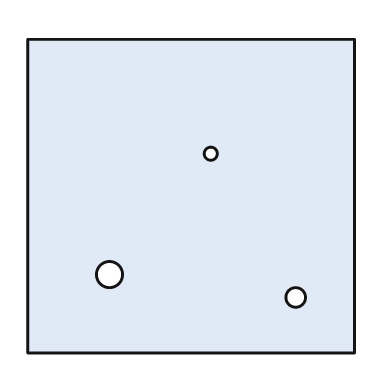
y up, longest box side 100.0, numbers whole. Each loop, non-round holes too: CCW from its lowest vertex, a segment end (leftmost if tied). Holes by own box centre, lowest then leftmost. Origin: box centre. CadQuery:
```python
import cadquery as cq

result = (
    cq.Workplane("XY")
    .moveTo(-50.0, -48.0)
    .lineTo(50.0, -48.0)
    .lineTo(50.0, 48.0)
    .lineTo(-50.0, 48.0)
    .close()
    .moveTo(32.0, -31.0)
    .circle(3.0)
    .moveTo(-25.0, -24.0)
    .circle(4.0)
    .moveTo(6.0, 13.0)
    .circle(2.0)
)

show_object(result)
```